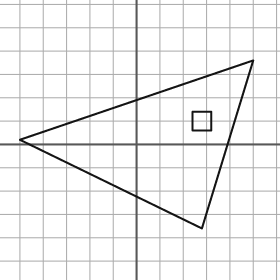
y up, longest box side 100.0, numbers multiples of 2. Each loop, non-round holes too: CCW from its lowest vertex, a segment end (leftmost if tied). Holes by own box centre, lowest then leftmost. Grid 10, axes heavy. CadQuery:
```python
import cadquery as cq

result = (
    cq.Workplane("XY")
    .moveTo(28.0, -36.0)
    .lineTo(50.0, 36.0)
    .lineTo(-50.0, 2.0)
    .close()
    .moveTo(24.0, 6.0)
    .lineTo(32.0, 6.0)
    .lineTo(32.0, 14.0)
    .lineTo(24.0, 14.0)
    .close()
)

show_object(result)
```